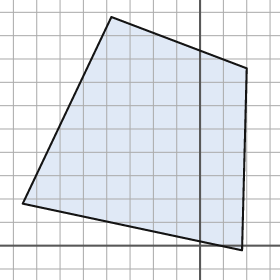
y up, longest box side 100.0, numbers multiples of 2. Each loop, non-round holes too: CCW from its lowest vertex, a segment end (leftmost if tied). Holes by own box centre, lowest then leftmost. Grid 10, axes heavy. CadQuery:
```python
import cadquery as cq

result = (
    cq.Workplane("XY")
    .moveTo(18.0, -2.0)
    .lineTo(20.0, 76.0)
    .lineTo(-38.0, 98.0)
    .lineTo(-76.0, 18.0)
    .close()
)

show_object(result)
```